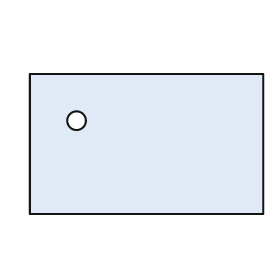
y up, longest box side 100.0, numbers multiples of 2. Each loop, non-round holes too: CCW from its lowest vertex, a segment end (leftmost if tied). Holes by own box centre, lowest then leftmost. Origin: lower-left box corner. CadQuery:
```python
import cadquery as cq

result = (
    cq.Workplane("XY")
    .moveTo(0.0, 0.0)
    .lineTo(100.0, 0.0)
    .lineTo(100.0, 60.0)
    .lineTo(0.0, 60.0)
    .close()
    .moveTo(20.0, 40.0)
    .circle(4.0)
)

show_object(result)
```